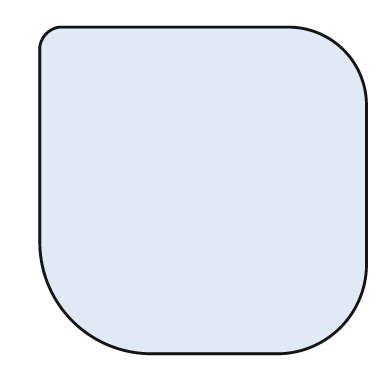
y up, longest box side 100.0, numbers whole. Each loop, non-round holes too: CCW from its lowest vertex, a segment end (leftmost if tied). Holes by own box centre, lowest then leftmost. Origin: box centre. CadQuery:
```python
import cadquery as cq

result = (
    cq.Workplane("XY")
    .moveTo(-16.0, -50.0)
    .lineTo(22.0, -50.0)
    .threePointArc((42.0, -42.0), (50.0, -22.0))
    .lineTo(50.0, 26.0)
    .threePointArc((43.0, 43.0), (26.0, 50.0))
    .lineTo(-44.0, 50.0)
    .threePointArc((-48.0, 48.0), (-50.0, 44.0))
    .lineTo(-50.0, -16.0)
    .threePointArc((-40.0, -40.0), (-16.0, -50.0))
    .close()
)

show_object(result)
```